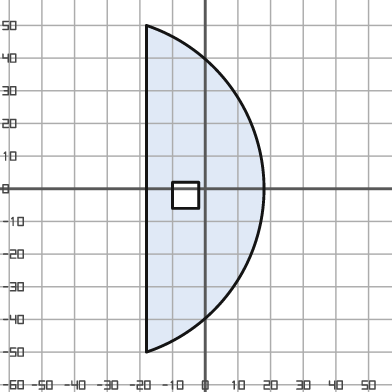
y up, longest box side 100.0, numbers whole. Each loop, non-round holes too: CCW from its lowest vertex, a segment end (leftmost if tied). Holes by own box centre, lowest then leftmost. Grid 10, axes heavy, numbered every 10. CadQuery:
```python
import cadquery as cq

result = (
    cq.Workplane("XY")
    .moveTo(-18.0, -50.0)
    .threePointArc((18.0, 0.0), (-18.0, 50.0))
    .close()
    .moveTo(-10.0, -6.0)
    .lineTo(-2.0, -6.0)
    .lineTo(-2.0, 2.0)
    .lineTo(-10.0, 2.0)
    .close()
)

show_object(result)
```